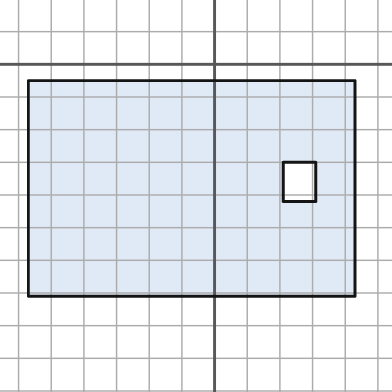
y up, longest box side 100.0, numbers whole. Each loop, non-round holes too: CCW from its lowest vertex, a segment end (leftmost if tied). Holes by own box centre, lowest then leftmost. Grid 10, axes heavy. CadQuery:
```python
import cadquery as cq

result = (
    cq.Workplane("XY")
    .moveTo(-57.0, -71.0)
    .lineTo(43.0, -71.0)
    .lineTo(43.0, -5.0)
    .lineTo(-57.0, -5.0)
    .close()
    .moveTo(21.0, -42.0)
    .lineTo(31.0, -42.0)
    .lineTo(31.0, -30.0)
    .lineTo(21.0, -30.0)
    .close()
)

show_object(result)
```